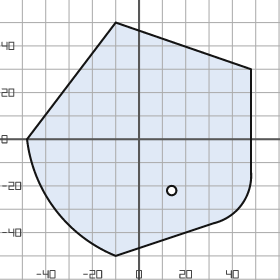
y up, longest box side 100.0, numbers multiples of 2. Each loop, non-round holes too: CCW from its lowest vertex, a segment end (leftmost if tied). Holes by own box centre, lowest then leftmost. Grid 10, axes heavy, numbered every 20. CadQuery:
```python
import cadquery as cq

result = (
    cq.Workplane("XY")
    .moveTo(-10.0, -50.0)
    .lineTo(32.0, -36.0)
    .threePointArc((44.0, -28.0), (48.0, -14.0))
    .lineTo(48.0, 30.0)
    .lineTo(-10.0, 50.0)
    .lineTo(-48.0, 0.0)
    .threePointArc((-36.0, -30.0), (-10.0, -50.0))
    .close()
    .moveTo(14.0, -22.0)
    .circle(2.0)
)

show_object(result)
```